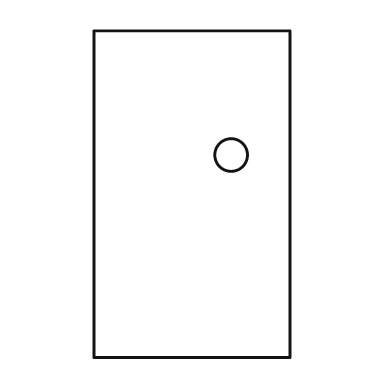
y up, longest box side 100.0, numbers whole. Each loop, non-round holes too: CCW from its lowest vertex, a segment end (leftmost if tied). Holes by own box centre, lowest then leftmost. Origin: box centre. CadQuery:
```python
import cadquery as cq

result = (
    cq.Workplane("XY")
    .moveTo(-30.0, -50.0)
    .lineTo(30.0, -50.0)
    .lineTo(30.0, 50.0)
    .lineTo(-30.0, 50.0)
    .close()
    .moveTo(12.0, 12.0)
    .circle(5.0)
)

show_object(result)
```